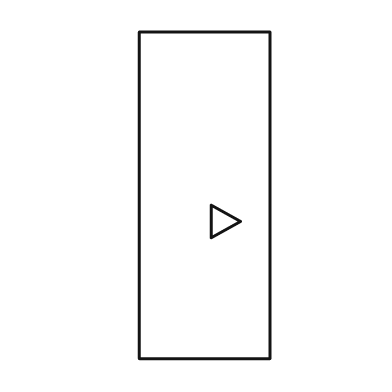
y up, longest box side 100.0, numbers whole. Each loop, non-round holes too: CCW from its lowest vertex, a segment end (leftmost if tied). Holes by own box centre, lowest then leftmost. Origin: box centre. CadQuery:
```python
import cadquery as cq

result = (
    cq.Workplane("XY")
    .moveTo(-20.0, -50.0)
    .lineTo(20.0, -50.0)
    .lineTo(20.0, 50.0)
    .lineTo(-20.0, 50.0)
    .close()
    .moveTo(2.0, -13.0)
    .lineTo(11.0, -8.0)
    .lineTo(2.0, -3.0)
    .close()
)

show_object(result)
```